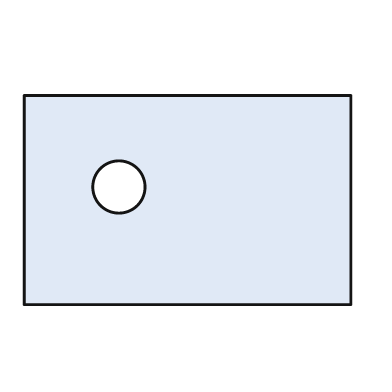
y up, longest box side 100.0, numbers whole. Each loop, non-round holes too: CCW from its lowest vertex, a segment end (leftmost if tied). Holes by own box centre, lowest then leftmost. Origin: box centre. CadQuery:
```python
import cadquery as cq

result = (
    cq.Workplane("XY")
    .moveTo(-50.0, -32.0)
    .lineTo(50.0, -32.0)
    .lineTo(50.0, 32.0)
    .lineTo(-50.0, 32.0)
    .close()
    .moveTo(-21.0, 4.0)
    .circle(8.0)
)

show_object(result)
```